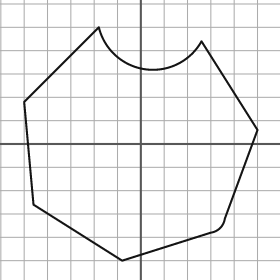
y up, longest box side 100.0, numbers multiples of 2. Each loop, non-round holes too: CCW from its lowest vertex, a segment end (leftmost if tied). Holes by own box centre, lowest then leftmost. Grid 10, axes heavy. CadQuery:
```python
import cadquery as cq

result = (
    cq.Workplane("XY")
    .moveTo(-8.0, -50.0)
    .lineTo(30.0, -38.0)
    .threePointArc((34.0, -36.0), (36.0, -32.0))
    .lineTo(50.0, 6.0)
    .lineTo(26.0, 44.0)
    .threePointArc((2.0, 32.0), (-18.0, 50.0))
    .lineTo(-50.0, 18.0)
    .lineTo(-46.0, -26.0)
    .close()
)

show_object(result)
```